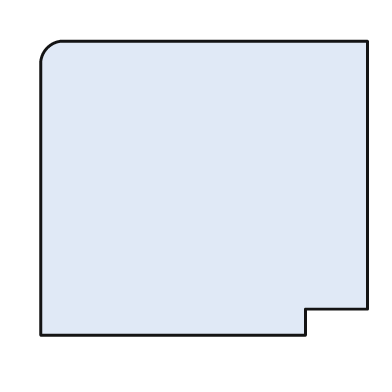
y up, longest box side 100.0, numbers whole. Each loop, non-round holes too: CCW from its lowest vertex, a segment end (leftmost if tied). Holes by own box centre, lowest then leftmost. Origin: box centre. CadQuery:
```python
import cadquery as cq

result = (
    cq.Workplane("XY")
    .moveTo(-50.0, -45.0)
    .lineTo(31.0, -45.0)
    .lineTo(31.0, -37.0)
    .lineTo(50.0, -37.0)
    .lineTo(50.0, 45.0)
    .lineTo(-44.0, 45.0)
    .threePointArc((-48.0, 43.0), (-50.0, 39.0))
    .close()
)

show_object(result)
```